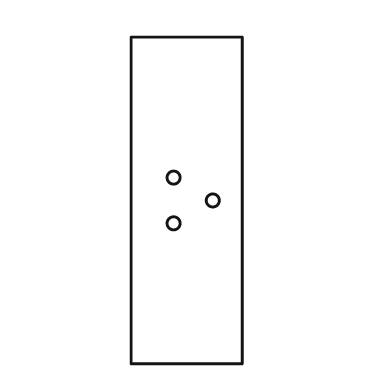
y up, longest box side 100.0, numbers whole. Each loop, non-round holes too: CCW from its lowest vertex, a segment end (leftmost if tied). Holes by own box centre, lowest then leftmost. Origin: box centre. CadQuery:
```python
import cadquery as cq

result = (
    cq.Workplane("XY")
    .moveTo(-17.0, -50.0)
    .lineTo(17.0, -50.0)
    .lineTo(17.0, 50.0)
    .lineTo(-17.0, 50.0)
    .close()
    .moveTo(-4.0, -7.0)
    .circle(2.0)
    .moveTo(8.0, 0.0)
    .circle(2.0)
    .moveTo(-4.0, 7.0)
    .circle(2.0)
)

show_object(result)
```